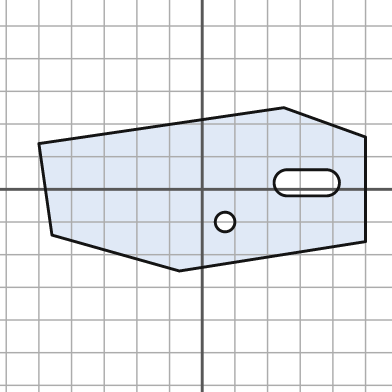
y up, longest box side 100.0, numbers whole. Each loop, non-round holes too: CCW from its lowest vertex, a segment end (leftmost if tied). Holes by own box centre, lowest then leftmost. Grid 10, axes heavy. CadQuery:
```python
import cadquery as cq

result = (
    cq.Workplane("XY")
    .moveTo(-7.0, -25.0)
    .lineTo(50.0, -16.0)
    .lineTo(50.0, 16.0)
    .lineTo(25.0, 25.0)
    .lineTo(-50.0, 14.0)
    .lineTo(-46.0, -14.0)
    .close()
    .moveTo(7.0, -10.0)
    .circle(3.0)
    .moveTo(26.0, -2.0)
    .lineTo(38.0, -2.0)
    .threePointArc((42.0, 2.0), (38.0, 6.0))
    .lineTo(26.0, 6.0)
    .threePointArc((22.0, 2.0), (26.0, -2.0))
    .close()
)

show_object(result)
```